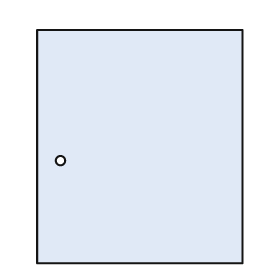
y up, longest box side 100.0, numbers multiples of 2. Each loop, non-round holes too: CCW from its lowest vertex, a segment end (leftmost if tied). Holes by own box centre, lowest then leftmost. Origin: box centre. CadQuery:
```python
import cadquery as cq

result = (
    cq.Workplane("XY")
    .moveTo(-44.0, -50.0)
    .lineTo(44.0, -50.0)
    .lineTo(44.0, 50.0)
    .lineTo(-44.0, 50.0)
    .close()
    .moveTo(-34.0, -6.0)
    .circle(2.0)
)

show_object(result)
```